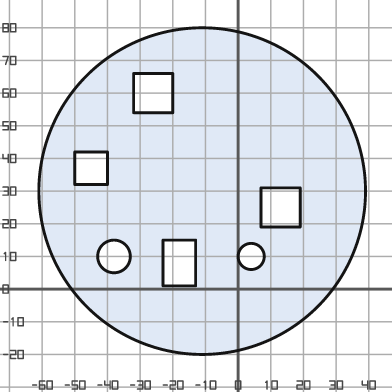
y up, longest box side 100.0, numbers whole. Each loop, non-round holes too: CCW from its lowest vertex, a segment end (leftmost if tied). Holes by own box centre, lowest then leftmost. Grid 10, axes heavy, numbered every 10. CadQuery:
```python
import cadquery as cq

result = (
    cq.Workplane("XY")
    .moveTo(-11.0, 30.0)
    .circle(50.0)
    .moveTo(-23.0, 1.0)
    .lineTo(-13.0, 1.0)
    .lineTo(-13.0, 15.0)
    .lineTo(-23.0, 15.0)
    .close()
    .moveTo(-38.0, 10.0)
    .circle(5.0)
    .moveTo(4.0, 10.0)
    .circle(4.0)
    .moveTo(7.0, 19.0)
    .lineTo(19.0, 19.0)
    .lineTo(19.0, 31.0)
    .lineTo(7.0, 31.0)
    .close()
    .moveTo(-50.0, 32.0)
    .lineTo(-40.0, 32.0)
    .lineTo(-40.0, 42.0)
    .lineTo(-50.0, 42.0)
    .close()
    .moveTo(-32.0, 54.0)
    .lineTo(-20.0, 54.0)
    .lineTo(-20.0, 66.0)
    .lineTo(-32.0, 66.0)
    .close()
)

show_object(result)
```